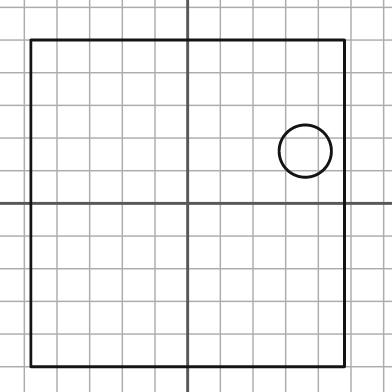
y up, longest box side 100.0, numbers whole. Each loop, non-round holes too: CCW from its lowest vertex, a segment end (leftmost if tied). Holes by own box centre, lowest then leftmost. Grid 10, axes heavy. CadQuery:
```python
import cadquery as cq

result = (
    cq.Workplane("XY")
    .moveTo(-48.0, -50.0)
    .lineTo(48.0, -50.0)
    .lineTo(48.0, 50.0)
    .lineTo(-48.0, 50.0)
    .close()
    .moveTo(36.0, 16.0)
    .circle(8.0)
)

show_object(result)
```